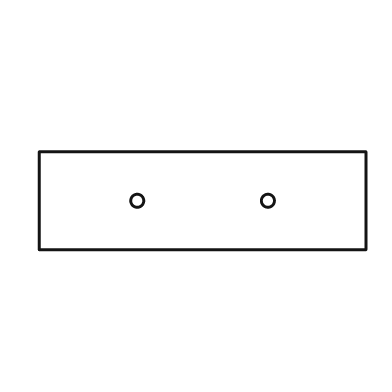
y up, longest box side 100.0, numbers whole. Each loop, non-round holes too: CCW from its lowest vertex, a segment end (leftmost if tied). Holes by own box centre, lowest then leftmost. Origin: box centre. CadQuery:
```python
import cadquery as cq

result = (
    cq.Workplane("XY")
    .moveTo(-50.0, -15.0)
    .lineTo(50.0, -15.0)
    .lineTo(50.0, 15.0)
    .lineTo(-50.0, 15.0)
    .close()
    .moveTo(-20.0, 0.0)
    .circle(2.0)
    .moveTo(20.0, 0.0)
    .circle(2.0)
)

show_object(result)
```